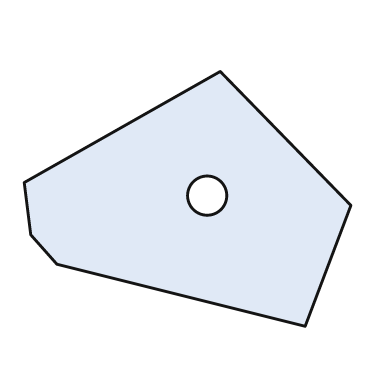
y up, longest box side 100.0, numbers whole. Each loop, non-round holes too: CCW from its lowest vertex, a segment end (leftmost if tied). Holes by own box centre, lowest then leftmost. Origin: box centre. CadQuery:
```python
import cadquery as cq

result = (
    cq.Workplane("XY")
    .moveTo(36.0, -39.0)
    .lineTo(50.0, -2.0)
    .lineTo(10.0, 39.0)
    .lineTo(-50.0, 5.0)
    .lineTo(-48.0, -11.0)
    .lineTo(-40.0, -20.0)
    .close()
    .moveTo(6.0, 1.0)
    .circle(6.0)
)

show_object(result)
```